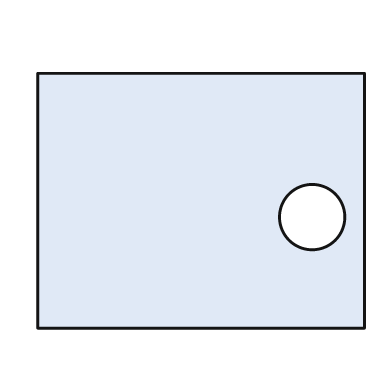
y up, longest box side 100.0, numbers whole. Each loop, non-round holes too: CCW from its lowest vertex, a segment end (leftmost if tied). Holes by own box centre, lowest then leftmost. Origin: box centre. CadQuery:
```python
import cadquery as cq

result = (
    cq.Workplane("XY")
    .moveTo(-50.0, -39.0)
    .lineTo(50.0, -39.0)
    .lineTo(50.0, 39.0)
    .lineTo(-50.0, 39.0)
    .close()
    .moveTo(34.0, -5.0)
    .circle(10.0)
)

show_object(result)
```